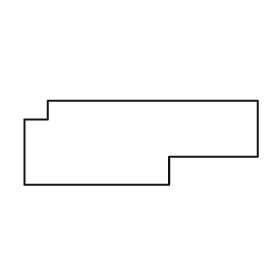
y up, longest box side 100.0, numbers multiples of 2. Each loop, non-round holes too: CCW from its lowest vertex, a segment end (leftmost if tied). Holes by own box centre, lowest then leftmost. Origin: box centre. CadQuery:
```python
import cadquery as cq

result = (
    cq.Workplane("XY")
    .moveTo(-50.0, -18.0)
    .lineTo(12.0, -18.0)
    .lineTo(12.0, -6.0)
    .lineTo(50.0, -6.0)
    .lineTo(50.0, 18.0)
    .lineTo(-40.0, 18.0)
    .lineTo(-40.0, 10.0)
    .lineTo(-50.0, 10.0)
    .close()
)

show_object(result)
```